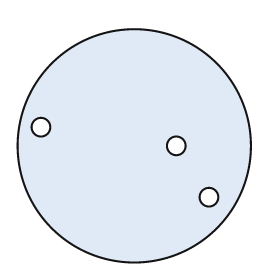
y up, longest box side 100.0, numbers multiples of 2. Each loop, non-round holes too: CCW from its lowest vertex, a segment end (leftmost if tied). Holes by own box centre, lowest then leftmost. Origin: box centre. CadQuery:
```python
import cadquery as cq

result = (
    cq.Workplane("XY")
    .moveTo(0.0, 0.0)
    .circle(50.0)
    .moveTo(32.0, -22.0)
    .circle(4.0)
    .moveTo(18.0, 0.0)
    .circle(4.0)
    .moveTo(-40.0, 8.0)
    .circle(4.0)
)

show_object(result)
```